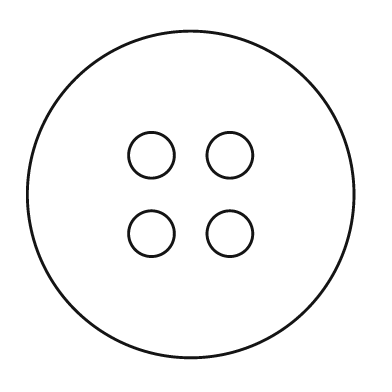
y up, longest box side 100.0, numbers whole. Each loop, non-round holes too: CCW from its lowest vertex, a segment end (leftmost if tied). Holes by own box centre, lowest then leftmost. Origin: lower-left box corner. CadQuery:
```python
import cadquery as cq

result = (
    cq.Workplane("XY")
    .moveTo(50.0, 50.0)
    .circle(50.0)
    .moveTo(38.0, 38.0)
    .circle(7.0)
    .moveTo(62.0, 38.0)
    .circle(7.0)
    .moveTo(38.0, 62.0)
    .circle(7.0)
    .moveTo(62.0, 62.0)
    .circle(7.0)
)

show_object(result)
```